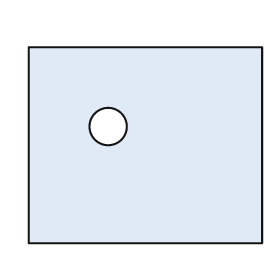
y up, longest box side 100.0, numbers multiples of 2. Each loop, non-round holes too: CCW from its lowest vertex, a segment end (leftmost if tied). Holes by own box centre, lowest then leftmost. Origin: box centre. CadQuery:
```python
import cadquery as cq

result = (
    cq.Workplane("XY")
    .moveTo(-50.0, -42.0)
    .lineTo(50.0, -42.0)
    .lineTo(50.0, 42.0)
    .lineTo(-50.0, 42.0)
    .close()
    .moveTo(-16.0, 8.0)
    .circle(8.0)
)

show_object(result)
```